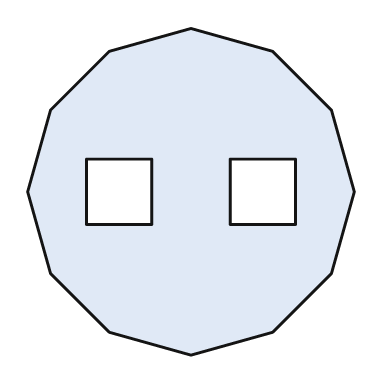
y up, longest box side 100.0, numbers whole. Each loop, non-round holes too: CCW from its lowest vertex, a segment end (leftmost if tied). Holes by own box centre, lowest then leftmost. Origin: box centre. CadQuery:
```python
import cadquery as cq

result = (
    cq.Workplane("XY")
    .moveTo(0.0, -50.0)
    .lineTo(25.0, -43.0)
    .lineTo(43.0, -25.0)
    .lineTo(50.0, 0.0)
    .lineTo(43.0, 25.0)
    .lineTo(25.0, 43.0)
    .lineTo(0.0, 50.0)
    .lineTo(-25.0, 43.0)
    .lineTo(-43.0, 25.0)
    .lineTo(-50.0, 0.0)
    .lineTo(-43.0, -25.0)
    .lineTo(-25.0, -43.0)
    .close()
    .moveTo(-32.0, -10.0)
    .lineTo(-12.0, -10.0)
    .lineTo(-12.0, 10.0)
    .lineTo(-32.0, 10.0)
    .close()
    .moveTo(12.0, -10.0)
    .lineTo(32.0, -10.0)
    .lineTo(32.0, 10.0)
    .lineTo(12.0, 10.0)
    .close()
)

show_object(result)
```